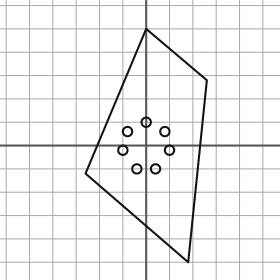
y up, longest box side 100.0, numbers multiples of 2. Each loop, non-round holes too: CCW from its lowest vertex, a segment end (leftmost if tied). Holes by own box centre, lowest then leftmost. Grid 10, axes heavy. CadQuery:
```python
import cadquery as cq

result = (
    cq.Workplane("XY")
    .moveTo(18.0, -50.0)
    .lineTo(26.0, 28.0)
    .lineTo(0.0, 50.0)
    .lineTo(-26.0, -12.0)
    .close()
    .moveTo(-4.0, -10.0)
    .circle(2.0)
    .moveTo(4.0, -10.0)
    .circle(2.0)
    .moveTo(-10.0, -2.0)
    .circle(2.0)
    .moveTo(10.0, -2.0)
    .circle(2.0)
    .moveTo(-8.0, 6.0)
    .circle(2.0)
    .moveTo(8.0, 6.0)
    .circle(2.0)
    .moveTo(0.0, 10.0)
    .circle(2.0)
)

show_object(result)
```